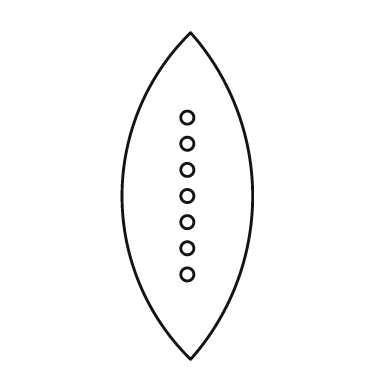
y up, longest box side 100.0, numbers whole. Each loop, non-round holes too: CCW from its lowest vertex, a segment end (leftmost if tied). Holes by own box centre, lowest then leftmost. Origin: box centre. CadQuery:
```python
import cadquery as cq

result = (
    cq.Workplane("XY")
    .moveTo(1.0, -50.0)
    .threePointArc((20.0, 0.0), (1.0, 50.0))
    .threePointArc((-20.0, 0.0), (1.0, -50.0))
    .close()
    .moveTo(0.0, -24.0)
    .circle(2.0)
    .moveTo(0.0, -16.0)
    .circle(2.0)
    .moveTo(0.0, -8.0)
    .circle(2.0)
    .moveTo(0.0, 0.0)
    .circle(2.0)
    .moveTo(0.0, 8.0)
    .circle(2.0)
    .moveTo(0.0, 16.0)
    .circle(2.0)
    .moveTo(0.0, 24.0)
    .circle(2.0)
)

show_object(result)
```